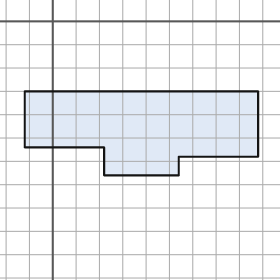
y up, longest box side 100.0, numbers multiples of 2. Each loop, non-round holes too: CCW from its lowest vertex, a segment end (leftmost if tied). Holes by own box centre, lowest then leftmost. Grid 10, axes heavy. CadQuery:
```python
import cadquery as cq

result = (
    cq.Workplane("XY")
    .moveTo(22.0, -66.0)
    .lineTo(54.0, -66.0)
    .lineTo(54.0, -58.0)
    .lineTo(88.0, -58.0)
    .lineTo(88.0, -30.0)
    .lineTo(-12.0, -30.0)
    .lineTo(-12.0, -54.0)
    .lineTo(22.0, -54.0)
    .close()
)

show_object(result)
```